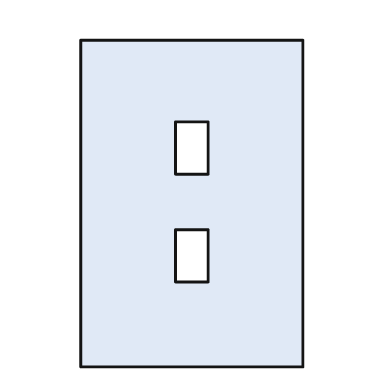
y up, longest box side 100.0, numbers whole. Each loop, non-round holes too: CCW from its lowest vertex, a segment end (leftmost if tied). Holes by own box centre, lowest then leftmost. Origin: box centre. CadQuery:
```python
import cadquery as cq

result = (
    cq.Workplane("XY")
    .moveTo(-34.0, -50.0)
    .lineTo(34.0, -50.0)
    .lineTo(34.0, 50.0)
    .lineTo(-34.0, 50.0)
    .close()
    .moveTo(-5.0, -24.0)
    .lineTo(5.0, -24.0)
    .lineTo(5.0, -8.0)
    .lineTo(-5.0, -8.0)
    .close()
    .moveTo(-5.0, 9.0)
    .lineTo(5.0, 9.0)
    .lineTo(5.0, 25.0)
    .lineTo(-5.0, 25.0)
    .close()
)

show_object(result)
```